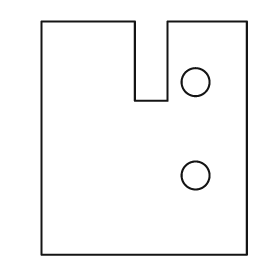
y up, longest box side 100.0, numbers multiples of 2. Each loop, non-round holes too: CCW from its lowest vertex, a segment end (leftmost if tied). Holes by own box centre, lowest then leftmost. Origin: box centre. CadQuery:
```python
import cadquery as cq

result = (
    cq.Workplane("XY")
    .moveTo(-44.0, -50.0)
    .lineTo(44.0, -50.0)
    .lineTo(44.0, 50.0)
    .lineTo(10.0, 50.0)
    .lineTo(10.0, 16.0)
    .lineTo(-4.0, 16.0)
    .lineTo(-4.0, 50.0)
    .lineTo(-44.0, 50.0)
    .close()
    .moveTo(22.0, -16.0)
    .circle(6.0)
    .moveTo(22.0, 24.0)
    .circle(6.0)
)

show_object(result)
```